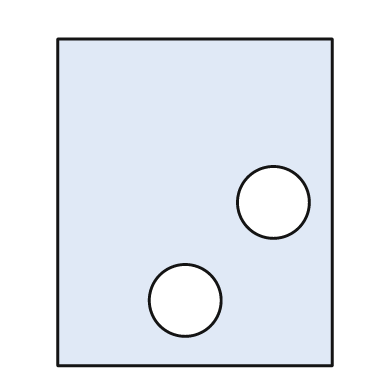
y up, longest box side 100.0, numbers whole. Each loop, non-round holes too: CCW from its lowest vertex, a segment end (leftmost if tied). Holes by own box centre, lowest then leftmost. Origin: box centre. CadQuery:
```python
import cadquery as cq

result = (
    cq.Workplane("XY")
    .moveTo(-42.0, -50.0)
    .lineTo(42.0, -50.0)
    .lineTo(42.0, 50.0)
    .lineTo(-42.0, 50.0)
    .close()
    .moveTo(-3.0, -30.0)
    .circle(11.0)
    .moveTo(24.0, 0.0)
    .circle(11.0)
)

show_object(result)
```